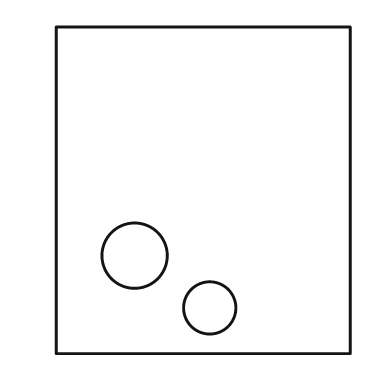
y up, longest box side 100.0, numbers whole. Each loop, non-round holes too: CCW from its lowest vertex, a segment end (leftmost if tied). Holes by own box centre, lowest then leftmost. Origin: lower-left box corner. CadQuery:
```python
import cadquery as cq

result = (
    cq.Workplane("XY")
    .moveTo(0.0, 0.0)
    .lineTo(90.0, 0.0)
    .lineTo(90.0, 100.0)
    .lineTo(0.0, 100.0)
    .close()
    .moveTo(47.0, 14.0)
    .circle(8.0)
    .moveTo(24.0, 30.0)
    .circle(10.0)
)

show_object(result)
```